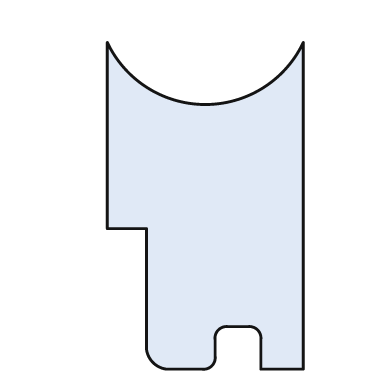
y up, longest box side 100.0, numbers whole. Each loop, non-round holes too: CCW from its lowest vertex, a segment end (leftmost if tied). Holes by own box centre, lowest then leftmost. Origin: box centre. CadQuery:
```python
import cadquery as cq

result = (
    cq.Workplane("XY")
    .moveTo(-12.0, -50.0)
    .lineTo(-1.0, -50.0)
    .threePointArc((2.0, -49.0), (3.0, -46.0))
    .lineTo(3.0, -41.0)
    .threePointArc((4.0, -38.0), (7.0, -37.0))
    .lineTo(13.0, -37.0)
    .threePointArc((16.0, -38.0), (17.0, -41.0))
    .lineTo(17.0, -50.0)
    .lineTo(30.0, -50.0)
    .lineTo(30.0, 50.0)
    .threePointArc((0.0, 31.0), (-30.0, 50.0))
    .lineTo(-30.0, -7.0)
    .lineTo(-18.0, -7.0)
    .lineTo(-18.0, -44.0)
    .threePointArc((-16.0, -48.0), (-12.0, -50.0))
    .close()
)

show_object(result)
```